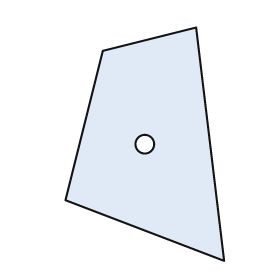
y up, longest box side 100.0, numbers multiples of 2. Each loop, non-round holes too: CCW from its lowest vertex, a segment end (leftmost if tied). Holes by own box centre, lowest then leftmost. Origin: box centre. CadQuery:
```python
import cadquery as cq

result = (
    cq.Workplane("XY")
    .moveTo(34.0, -50.0)
    .lineTo(22.0, 50.0)
    .lineTo(-18.0, 40.0)
    .lineTo(-34.0, -24.0)
    .close()
    .moveTo(0.0, 0.0)
    .circle(4.0)
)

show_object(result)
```